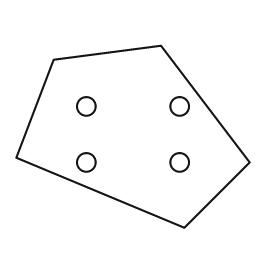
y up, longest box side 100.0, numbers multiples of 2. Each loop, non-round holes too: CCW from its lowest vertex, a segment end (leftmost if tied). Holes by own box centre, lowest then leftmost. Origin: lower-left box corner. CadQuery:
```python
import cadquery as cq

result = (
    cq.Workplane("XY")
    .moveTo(72.0, 0.0)
    .lineTo(100.0, 28.0)
    .lineTo(62.0, 78.0)
    .lineTo(16.0, 72.0)
    .lineTo(0.0, 30.0)
    .close()
    .moveTo(30.0, 28.0)
    .circle(4.0)
    .moveTo(70.0, 28.0)
    .circle(4.0)
    .moveTo(30.0, 52.0)
    .circle(4.0)
    .moveTo(70.0, 52.0)
    .circle(4.0)
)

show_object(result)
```